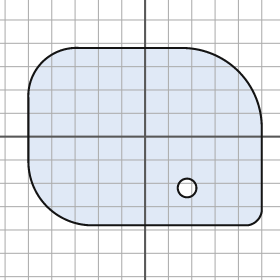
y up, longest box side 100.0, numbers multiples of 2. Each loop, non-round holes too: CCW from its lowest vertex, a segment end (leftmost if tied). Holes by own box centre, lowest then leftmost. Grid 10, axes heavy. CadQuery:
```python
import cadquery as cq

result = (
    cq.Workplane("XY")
    .moveTo(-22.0, -38.0)
    .lineTo(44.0, -38.0)
    .threePointArc((48.0, -36.0), (50.0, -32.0))
    .lineTo(50.0, 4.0)
    .threePointArc((40.0, 28.0), (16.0, 38.0))
    .lineTo(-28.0, 38.0)
    .threePointArc((-44.0, 32.0), (-50.0, 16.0))
    .lineTo(-50.0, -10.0)
    .threePointArc((-42.0, -30.0), (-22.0, -38.0))
    .close()
    .moveTo(18.0, -22.0)
    .circle(4.0)
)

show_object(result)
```